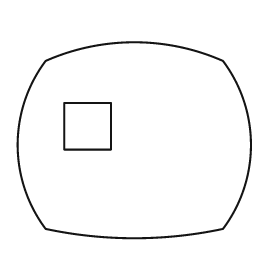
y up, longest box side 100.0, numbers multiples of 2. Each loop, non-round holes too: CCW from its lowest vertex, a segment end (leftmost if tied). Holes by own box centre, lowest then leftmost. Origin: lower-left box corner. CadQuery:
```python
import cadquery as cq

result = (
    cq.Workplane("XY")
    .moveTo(12.0, 4.0)
    .threePointArc((50.0, 0.0), (88.0, 4.0))
    .threePointArc((100.0, 40.0), (88.0, 76.0))
    .threePointArc((50.0, 84.0), (12.0, 76.0))
    .threePointArc((0.0, 40.0), (12.0, 4.0))
    .close()
    .moveTo(20.0, 38.0)
    .lineTo(40.0, 38.0)
    .lineTo(40.0, 58.0)
    .lineTo(20.0, 58.0)
    .close()
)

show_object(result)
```